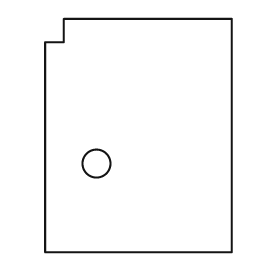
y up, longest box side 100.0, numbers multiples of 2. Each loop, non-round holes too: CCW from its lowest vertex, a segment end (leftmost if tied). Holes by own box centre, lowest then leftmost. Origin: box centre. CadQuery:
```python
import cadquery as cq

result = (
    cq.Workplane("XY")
    .moveTo(-40.0, -50.0)
    .lineTo(40.0, -50.0)
    .lineTo(40.0, 50.0)
    .lineTo(-32.0, 50.0)
    .lineTo(-32.0, 40.0)
    .lineTo(-40.0, 40.0)
    .close()
    .moveTo(-18.0, -12.0)
    .circle(6.0)
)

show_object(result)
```